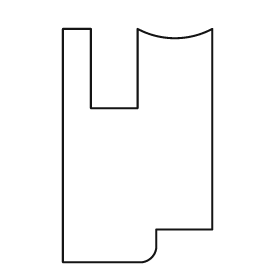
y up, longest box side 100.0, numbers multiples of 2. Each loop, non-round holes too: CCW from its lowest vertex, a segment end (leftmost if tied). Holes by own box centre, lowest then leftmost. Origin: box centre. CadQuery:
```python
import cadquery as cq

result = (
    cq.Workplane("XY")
    .moveTo(-32.0, -50.0)
    .lineTo(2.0, -50.0)
    .threePointArc((6.0, -48.0), (8.0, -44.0))
    .lineTo(8.0, -36.0)
    .lineTo(32.0, -36.0)
    .lineTo(32.0, 50.0)
    .threePointArc((16.0, 46.0), (0.0, 50.0))
    .lineTo(0.0, 16.0)
    .lineTo(-20.0, 16.0)
    .lineTo(-20.0, 50.0)
    .lineTo(-32.0, 50.0)
    .close()
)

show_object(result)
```